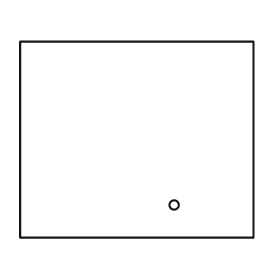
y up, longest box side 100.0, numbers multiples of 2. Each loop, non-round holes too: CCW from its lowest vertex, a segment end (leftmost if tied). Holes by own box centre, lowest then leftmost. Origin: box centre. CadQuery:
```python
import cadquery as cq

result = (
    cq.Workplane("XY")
    .moveTo(-50.0, -42.0)
    .lineTo(50.0, -42.0)
    .lineTo(50.0, 42.0)
    .lineTo(-50.0, 42.0)
    .close()
    .moveTo(16.0, -28.0)
    .circle(2.0)
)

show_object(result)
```